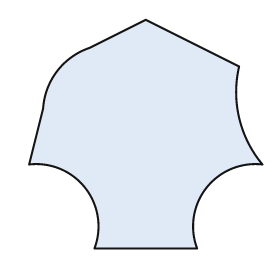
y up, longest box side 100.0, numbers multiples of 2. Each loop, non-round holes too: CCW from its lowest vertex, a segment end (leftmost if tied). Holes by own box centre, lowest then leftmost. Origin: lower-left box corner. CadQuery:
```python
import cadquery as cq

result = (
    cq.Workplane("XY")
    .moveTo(28.0, 0.0)
    .lineTo(72.0, 0.0)
    .threePointArc((76.0, 26.0), (100.0, 36.0))
    .threePointArc((90.0, 56.0), (90.0, 78.0))
    .lineTo(50.0, 98.0)
    .lineTo(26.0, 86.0)
    .threePointArc((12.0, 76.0), (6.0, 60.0))
    .lineTo(0.0, 36.0)
    .threePointArc((24.0, 26.0), (28.0, 0.0))
    .close()
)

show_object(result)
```